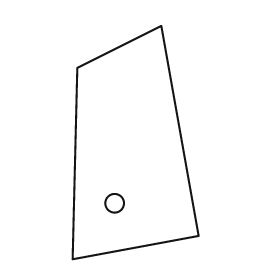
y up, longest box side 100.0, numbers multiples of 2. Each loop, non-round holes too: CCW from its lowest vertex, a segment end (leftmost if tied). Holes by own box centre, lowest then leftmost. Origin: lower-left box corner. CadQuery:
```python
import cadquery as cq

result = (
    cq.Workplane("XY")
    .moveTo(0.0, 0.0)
    .lineTo(54.0, 10.0)
    .lineTo(38.0, 100.0)
    .lineTo(2.0, 82.0)
    .close()
    .moveTo(18.0, 24.0)
    .circle(4.0)
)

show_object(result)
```